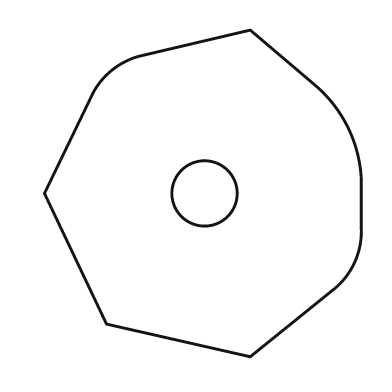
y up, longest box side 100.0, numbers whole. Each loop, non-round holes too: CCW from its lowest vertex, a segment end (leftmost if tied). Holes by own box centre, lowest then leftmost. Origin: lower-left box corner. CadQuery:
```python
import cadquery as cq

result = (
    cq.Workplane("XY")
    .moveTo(63.0, 0.0)
    .lineTo(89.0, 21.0)
    .threePointArc((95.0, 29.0), (97.0, 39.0))
    .lineTo(97.0, 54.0)
    .threePointArc((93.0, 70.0), (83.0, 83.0))
    .lineTo(63.0, 100.0)
    .lineTo(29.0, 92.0)
    .threePointArc((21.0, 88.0), (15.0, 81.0))
    .lineTo(0.0, 50.0)
    .lineTo(19.0, 10.0)
    .close()
    .moveTo(49.0, 50.0)
    .circle(10.0)
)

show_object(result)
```